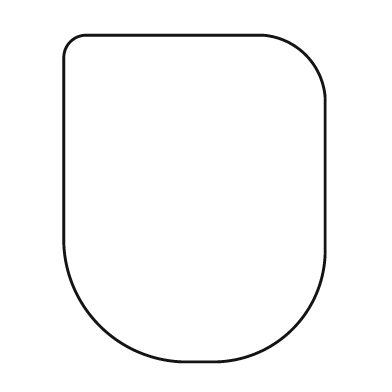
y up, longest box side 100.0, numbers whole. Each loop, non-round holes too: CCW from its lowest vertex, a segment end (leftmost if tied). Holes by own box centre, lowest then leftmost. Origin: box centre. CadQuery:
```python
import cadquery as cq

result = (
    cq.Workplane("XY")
    .moveTo(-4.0, -50.0)
    .lineTo(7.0, -50.0)
    .threePointArc((30.0, -40.0), (40.0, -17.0))
    .lineTo(40.0, 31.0)
    .threePointArc((34.0, 44.0), (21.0, 50.0))
    .lineTo(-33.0, 50.0)
    .threePointArc((-38.0, 48.0), (-40.0, 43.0))
    .lineTo(-40.0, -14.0)
    .threePointArc((-29.0, -39.0), (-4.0, -50.0))
    .close()
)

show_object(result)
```